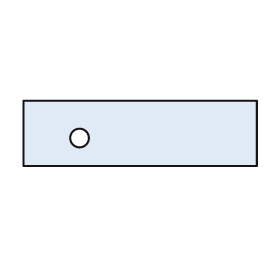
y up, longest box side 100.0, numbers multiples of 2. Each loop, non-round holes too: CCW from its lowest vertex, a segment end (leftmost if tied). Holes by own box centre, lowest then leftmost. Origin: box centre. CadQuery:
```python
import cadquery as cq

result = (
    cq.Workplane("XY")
    .moveTo(-50.0, -14.0)
    .lineTo(50.0, -14.0)
    .lineTo(50.0, 14.0)
    .lineTo(-50.0, 14.0)
    .close()
    .moveTo(-26.0, -2.0)
    .circle(4.0)
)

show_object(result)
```